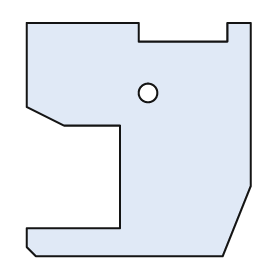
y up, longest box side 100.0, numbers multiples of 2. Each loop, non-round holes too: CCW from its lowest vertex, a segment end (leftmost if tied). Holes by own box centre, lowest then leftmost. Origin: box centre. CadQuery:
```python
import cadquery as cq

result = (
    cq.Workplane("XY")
    .moveTo(-44.0, -50.0)
    .lineTo(36.0, -50.0)
    .lineTo(48.0, -20.0)
    .lineTo(48.0, 50.0)
    .lineTo(38.0, 50.0)
    .lineTo(38.0, 42.0)
    .lineTo(0.0, 42.0)
    .lineTo(0.0, 50.0)
    .lineTo(-48.0, 50.0)
    .lineTo(-48.0, 14.0)
    .lineTo(-32.0, 6.0)
    .lineTo(-8.0, 6.0)
    .lineTo(-8.0, -38.0)
    .lineTo(-48.0, -38.0)
    .lineTo(-48.0, -46.0)
    .close()
    .moveTo(4.0, 20.0)
    .circle(4.0)
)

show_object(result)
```